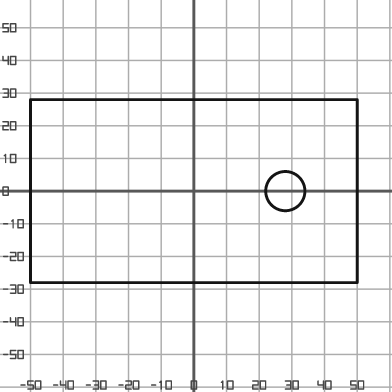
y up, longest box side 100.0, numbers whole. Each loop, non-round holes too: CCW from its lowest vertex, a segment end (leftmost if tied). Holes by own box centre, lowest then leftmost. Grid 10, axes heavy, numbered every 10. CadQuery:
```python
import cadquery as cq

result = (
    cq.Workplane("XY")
    .moveTo(-50.0, -28.0)
    .lineTo(50.0, -28.0)
    .lineTo(50.0, 28.0)
    .lineTo(-50.0, 28.0)
    .close()
    .moveTo(28.0, 0.0)
    .circle(6.0)
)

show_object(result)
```